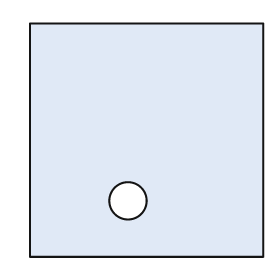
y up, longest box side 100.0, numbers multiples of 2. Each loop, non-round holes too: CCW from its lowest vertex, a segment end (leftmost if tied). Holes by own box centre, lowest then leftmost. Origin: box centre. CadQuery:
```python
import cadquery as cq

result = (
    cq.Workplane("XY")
    .moveTo(-50.0, -50.0)
    .lineTo(50.0, -50.0)
    .lineTo(50.0, 50.0)
    .lineTo(-50.0, 50.0)
    .close()
    .moveTo(-8.0, -26.0)
    .circle(8.0)
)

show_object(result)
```